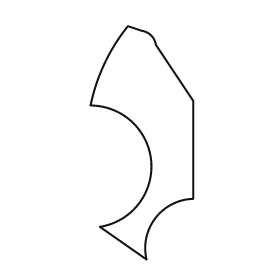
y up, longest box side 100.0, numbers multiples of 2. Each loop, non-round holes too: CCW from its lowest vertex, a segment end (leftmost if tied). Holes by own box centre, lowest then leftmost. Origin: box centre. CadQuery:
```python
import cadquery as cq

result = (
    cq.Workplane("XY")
    .moveTo(2.0, -50.0)
    .threePointArc((6.0, -32.0), (22.0, -24.0))
    .lineTo(22.0, 18.0)
    .lineTo(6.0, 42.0)
    .threePointArc((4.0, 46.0), (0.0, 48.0))
    .lineTo(-6.0, 50.0)
    .threePointArc((-16.0, 34.0), (-22.0, 16.0))
    .threePointArc((4.0, -8.0), (-18.0, -36.0))
    .close()
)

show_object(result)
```